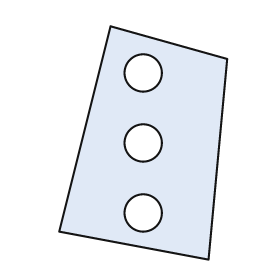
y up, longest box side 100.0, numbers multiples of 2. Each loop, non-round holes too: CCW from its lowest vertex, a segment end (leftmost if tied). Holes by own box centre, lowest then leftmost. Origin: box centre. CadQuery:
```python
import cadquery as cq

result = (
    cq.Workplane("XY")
    .moveTo(28.0, -50.0)
    .lineTo(36.0, 36.0)
    .lineTo(-14.0, 50.0)
    .lineTo(-36.0, -38.0)
    .close()
    .moveTo(0.0, -30.0)
    .circle(8.0)
    .moveTo(0.0, 0.0)
    .circle(8.0)
    .moveTo(0.0, 30.0)
    .circle(8.0)
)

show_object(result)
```